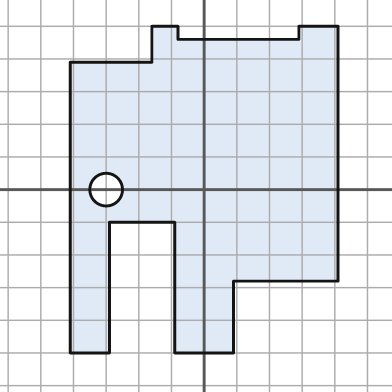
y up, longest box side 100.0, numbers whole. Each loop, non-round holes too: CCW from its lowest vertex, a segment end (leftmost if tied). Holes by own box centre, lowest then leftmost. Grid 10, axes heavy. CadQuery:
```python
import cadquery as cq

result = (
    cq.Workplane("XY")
    .moveTo(-41.0, -50.0)
    .lineTo(-29.0, -50.0)
    .lineTo(-29.0, -10.0)
    .lineTo(-9.0, -10.0)
    .lineTo(-9.0, -50.0)
    .lineTo(9.0, -50.0)
    .lineTo(9.0, -28.0)
    .lineTo(41.0, -28.0)
    .lineTo(41.0, 50.0)
    .lineTo(29.0, 50.0)
    .lineTo(29.0, 46.0)
    .lineTo(-8.0, 46.0)
    .lineTo(-8.0, 50.0)
    .lineTo(-16.0, 50.0)
    .lineTo(-16.0, 39.0)
    .lineTo(-41.0, 39.0)
    .close()
    .moveTo(-30.0, 0.0)
    .circle(5.0)
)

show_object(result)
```